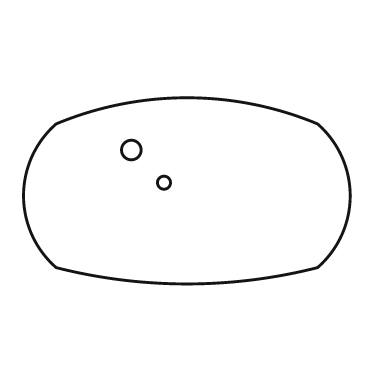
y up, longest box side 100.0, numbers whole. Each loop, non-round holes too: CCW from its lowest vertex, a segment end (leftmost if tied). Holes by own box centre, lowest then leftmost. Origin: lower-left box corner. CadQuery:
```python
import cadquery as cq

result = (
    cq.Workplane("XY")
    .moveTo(10.0, 5.0)
    .threePointArc((50.0, 0.0), (90.0, 5.0))
    .threePointArc((100.0, 27.0), (90.0, 49.0))
    .threePointArc((50.0, 57.0), (10.0, 49.0))
    .threePointArc((0.0, 27.0), (10.0, 5.0))
    .close()
    .moveTo(43.0, 31.0)
    .circle(2.0)
    .moveTo(33.0, 41.0)
    .circle(3.0)
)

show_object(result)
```